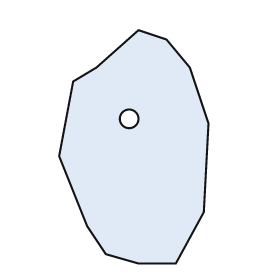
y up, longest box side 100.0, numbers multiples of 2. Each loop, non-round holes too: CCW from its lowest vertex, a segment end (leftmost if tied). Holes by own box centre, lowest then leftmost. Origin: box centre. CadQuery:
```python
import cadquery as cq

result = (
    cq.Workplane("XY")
    .moveTo(2.0, -50.0)
    .lineTo(18.0, -50.0)
    .lineTo(30.0, -28.0)
    .lineTo(32.0, 10.0)
    .lineTo(24.0, 34.0)
    .lineTo(14.0, 46.0)
    .lineTo(2.0, 50.0)
    .lineTo(-16.0, 34.0)
    .lineTo(-26.0, 28.0)
    .lineTo(-32.0, -4.0)
    .lineTo(-20.0, -34.0)
    .lineTo(-12.0, -46.0)
    .close()
    .moveTo(-2.0, 12.0)
    .circle(4.0)
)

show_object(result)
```